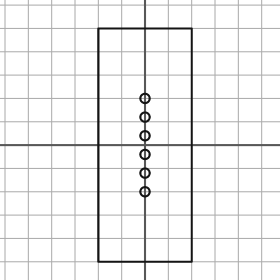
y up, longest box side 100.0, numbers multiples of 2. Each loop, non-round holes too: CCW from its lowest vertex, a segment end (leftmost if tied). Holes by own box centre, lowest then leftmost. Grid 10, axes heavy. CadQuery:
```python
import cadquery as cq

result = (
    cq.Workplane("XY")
    .moveTo(-20.0, -50.0)
    .lineTo(20.0, -50.0)
    .lineTo(20.0, 50.0)
    .lineTo(-20.0, 50.0)
    .close()
    .moveTo(0.0, -20.0)
    .circle(2.0)
    .moveTo(0.0, -12.0)
    .circle(2.0)
    .moveTo(0.0, -4.0)
    .circle(2.0)
    .moveTo(0.0, 4.0)
    .circle(2.0)
    .moveTo(0.0, 12.0)
    .circle(2.0)
    .moveTo(0.0, 20.0)
    .circle(2.0)
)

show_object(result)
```